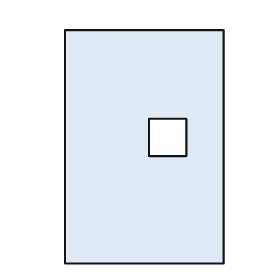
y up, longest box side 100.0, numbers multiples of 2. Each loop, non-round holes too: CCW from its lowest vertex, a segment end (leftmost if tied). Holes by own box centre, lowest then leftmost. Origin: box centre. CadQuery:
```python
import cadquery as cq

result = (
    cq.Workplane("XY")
    .moveTo(-34.0, -50.0)
    .lineTo(34.0, -50.0)
    .lineTo(34.0, 50.0)
    .lineTo(-34.0, 50.0)
    .close()
    .moveTo(2.0, -4.0)
    .lineTo(18.0, -4.0)
    .lineTo(18.0, 12.0)
    .lineTo(2.0, 12.0)
    .close()
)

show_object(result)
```